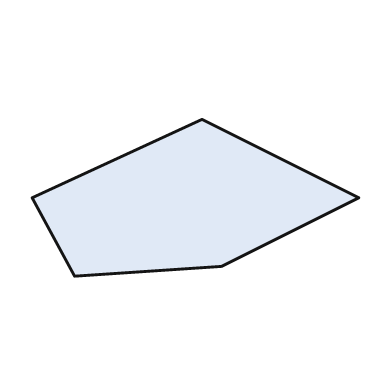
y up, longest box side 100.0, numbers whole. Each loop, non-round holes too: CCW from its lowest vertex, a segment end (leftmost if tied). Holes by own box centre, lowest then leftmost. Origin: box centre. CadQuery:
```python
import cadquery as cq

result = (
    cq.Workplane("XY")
    .moveTo(-37.0, -24.0)
    .lineTo(8.0, -21.0)
    .lineTo(50.0, 0.0)
    .lineTo(2.0, 24.0)
    .lineTo(-50.0, 0.0)
    .close()
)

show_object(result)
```